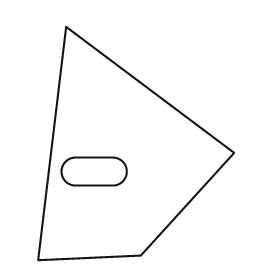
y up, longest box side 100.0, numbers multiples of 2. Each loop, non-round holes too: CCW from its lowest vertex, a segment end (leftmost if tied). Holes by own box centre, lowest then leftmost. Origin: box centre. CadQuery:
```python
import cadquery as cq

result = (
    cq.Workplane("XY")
    .moveTo(-42.0, -50.0)
    .lineTo(2.0, -48.0)
    .lineTo(42.0, -4.0)
    .lineTo(-30.0, 50.0)
    .close()
    .moveTo(-26.0, -18.0)
    .lineTo(-10.0, -18.0)
    .threePointArc((-4.0, -12.0), (-10.0, -6.0))
    .lineTo(-26.0, -6.0)
    .threePointArc((-32.0, -12.0), (-26.0, -18.0))
    .close()
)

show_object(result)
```